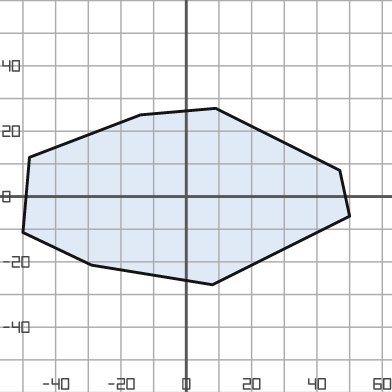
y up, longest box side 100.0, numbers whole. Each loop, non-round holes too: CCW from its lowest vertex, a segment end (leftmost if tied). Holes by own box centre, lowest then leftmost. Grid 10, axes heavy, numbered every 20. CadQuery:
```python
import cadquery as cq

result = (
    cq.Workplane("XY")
    .moveTo(8.0, -27.0)
    .lineTo(50.0, -6.0)
    .lineTo(47.0, 8.0)
    .lineTo(9.0, 27.0)
    .lineTo(-14.0, 25.0)
    .lineTo(-48.0, 12.0)
    .lineTo(-50.0, -11.0)
    .lineTo(-29.0, -21.0)
    .close()
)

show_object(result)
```